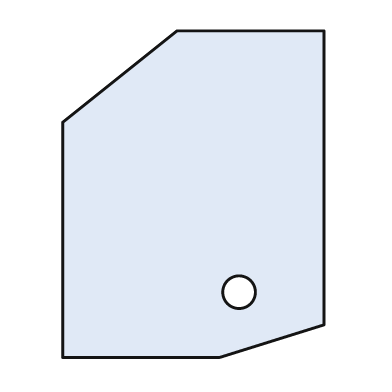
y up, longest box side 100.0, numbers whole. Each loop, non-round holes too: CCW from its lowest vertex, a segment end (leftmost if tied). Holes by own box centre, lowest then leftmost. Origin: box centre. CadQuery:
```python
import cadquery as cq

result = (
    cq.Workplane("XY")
    .moveTo(-40.0, -50.0)
    .lineTo(8.0, -50.0)
    .lineTo(40.0, -40.0)
    .lineTo(40.0, 50.0)
    .lineTo(-5.0, 50.0)
    .lineTo(-40.0, 22.0)
    .close()
    .moveTo(14.0, -30.0)
    .circle(5.0)
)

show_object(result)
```